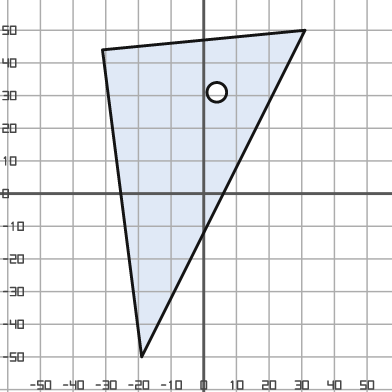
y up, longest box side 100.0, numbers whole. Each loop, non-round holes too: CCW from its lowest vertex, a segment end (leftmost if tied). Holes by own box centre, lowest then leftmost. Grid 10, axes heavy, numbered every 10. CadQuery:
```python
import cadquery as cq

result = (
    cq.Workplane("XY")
    .moveTo(-19.0, -50.0)
    .lineTo(31.0, 50.0)
    .lineTo(-31.0, 44.0)
    .close()
    .moveTo(4.0, 31.0)
    .circle(3.0)
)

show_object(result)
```